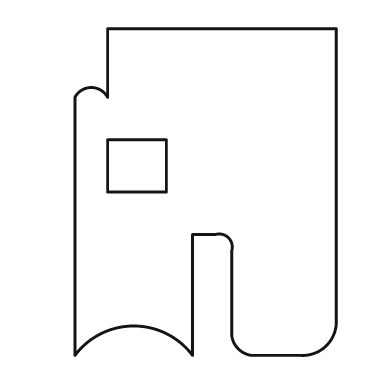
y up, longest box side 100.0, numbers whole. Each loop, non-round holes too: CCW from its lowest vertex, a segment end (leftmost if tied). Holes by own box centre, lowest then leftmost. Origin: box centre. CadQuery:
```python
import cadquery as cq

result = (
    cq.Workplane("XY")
    .moveTo(-40.0, -50.0)
    .threePointArc((-22.0, -41.0), (-4.0, -50.0))
    .lineTo(-4.0, -13.0)
    .lineTo(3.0, -13.0)
    .threePointArc((7.0, -14.0), (8.0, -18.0))
    .lineTo(8.0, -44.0)
    .threePointArc((10.0, -48.0), (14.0, -50.0))
    .lineTo(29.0, -50.0)
    .threePointArc((37.0, -47.0), (40.0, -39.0))
    .lineTo(40.0, 50.0)
    .lineTo(-30.0, 50.0)
    .lineTo(-30.0, 29.0)
    .threePointArc((-35.0, 32.0), (-40.0, 29.0))
    .close()
    .moveTo(-30.0, 0.0)
    .lineTo(-12.0, 0.0)
    .lineTo(-12.0, 16.0)
    .lineTo(-30.0, 16.0)
    .close()
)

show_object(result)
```